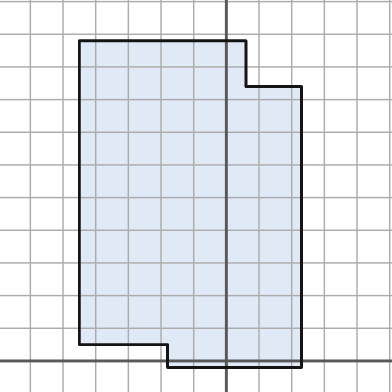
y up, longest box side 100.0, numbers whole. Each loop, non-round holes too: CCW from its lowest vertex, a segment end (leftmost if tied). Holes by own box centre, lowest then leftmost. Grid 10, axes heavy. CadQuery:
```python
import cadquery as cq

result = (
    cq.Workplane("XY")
    .moveTo(-18.0, -2.0)
    .lineTo(23.0, -2.0)
    .lineTo(23.0, 84.0)
    .lineTo(6.0, 84.0)
    .lineTo(6.0, 98.0)
    .lineTo(-45.0, 98.0)
    .lineTo(-45.0, 5.0)
    .lineTo(-18.0, 5.0)
    .close()
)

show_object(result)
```